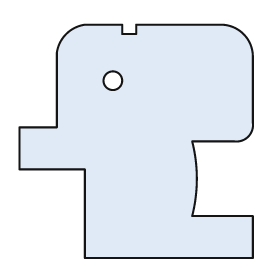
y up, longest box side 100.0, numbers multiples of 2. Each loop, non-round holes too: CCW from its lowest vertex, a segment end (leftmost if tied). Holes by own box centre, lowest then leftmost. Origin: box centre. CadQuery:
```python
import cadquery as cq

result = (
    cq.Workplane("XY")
    .moveTo(-22.0, -50.0)
    .lineTo(50.0, -50.0)
    .lineTo(50.0, -32.0)
    .lineTo(24.0, -32.0)
    .threePointArc((26.0, -16.0), (24.0, 0.0))
    .lineTo(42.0, 0.0)
    .threePointArc((48.0, 2.0), (50.0, 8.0))
    .lineTo(50.0, 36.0)
    .threePointArc((46.0, 46.0), (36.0, 50.0))
    .lineTo(0.0, 50.0)
    .lineTo(0.0, 46.0)
    .lineTo(-6.0, 46.0)
    .lineTo(-6.0, 50.0)
    .lineTo(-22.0, 50.0)
    .threePointArc((-30.0, 46.0), (-34.0, 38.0))
    .lineTo(-34.0, 6.0)
    .lineTo(-50.0, 6.0)
    .lineTo(-50.0, -12.0)
    .lineTo(-22.0, -12.0)
    .close()
    .moveTo(-10.0, 26.0)
    .circle(4.0)
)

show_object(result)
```